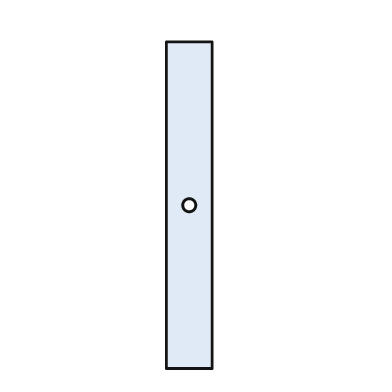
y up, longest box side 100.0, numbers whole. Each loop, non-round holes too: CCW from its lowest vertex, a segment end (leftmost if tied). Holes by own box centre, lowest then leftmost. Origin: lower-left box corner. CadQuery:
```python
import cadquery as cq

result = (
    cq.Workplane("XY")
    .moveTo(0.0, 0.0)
    .lineTo(14.0, 0.0)
    .lineTo(14.0, 100.0)
    .lineTo(0.0, 100.0)
    .close()
    .moveTo(7.0, 50.0)
    .circle(2.0)
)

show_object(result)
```